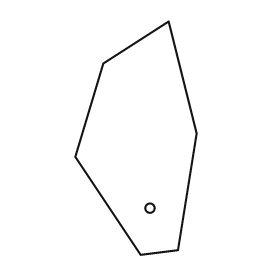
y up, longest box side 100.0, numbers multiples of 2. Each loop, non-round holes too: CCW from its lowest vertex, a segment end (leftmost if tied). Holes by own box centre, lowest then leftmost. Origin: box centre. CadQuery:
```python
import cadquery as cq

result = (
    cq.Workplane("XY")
    .moveTo(2.0, -50.0)
    .lineTo(18.0, -48.0)
    .lineTo(26.0, 2.0)
    .lineTo(14.0, 50.0)
    .lineTo(-14.0, 32.0)
    .lineTo(-26.0, -8.0)
    .close()
    .moveTo(6.0, -30.0)
    .circle(2.0)
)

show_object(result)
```